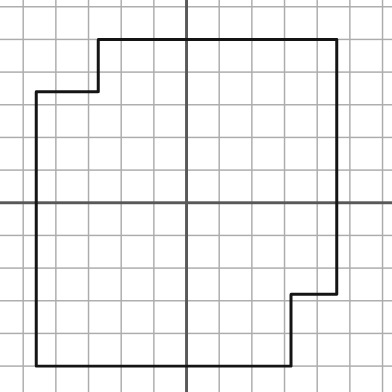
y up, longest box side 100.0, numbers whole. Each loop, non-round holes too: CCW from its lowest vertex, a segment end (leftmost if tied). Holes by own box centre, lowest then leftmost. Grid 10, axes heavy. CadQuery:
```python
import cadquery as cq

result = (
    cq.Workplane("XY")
    .moveTo(-46.0, -50.0)
    .lineTo(32.0, -50.0)
    .lineTo(32.0, -28.0)
    .lineTo(46.0, -28.0)
    .lineTo(46.0, 50.0)
    .lineTo(-27.0, 50.0)
    .lineTo(-27.0, 34.0)
    .lineTo(-46.0, 34.0)
    .close()
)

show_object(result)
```